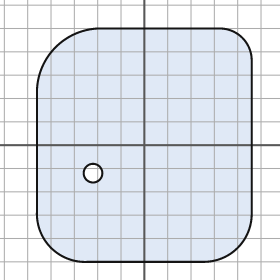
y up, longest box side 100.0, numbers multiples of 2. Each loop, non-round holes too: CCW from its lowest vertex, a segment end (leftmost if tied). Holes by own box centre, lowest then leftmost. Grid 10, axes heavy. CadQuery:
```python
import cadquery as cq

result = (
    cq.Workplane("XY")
    .moveTo(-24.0, -50.0)
    .lineTo(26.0, -50.0)
    .threePointArc((40.0, -44.0), (46.0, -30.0))
    .lineTo(46.0, 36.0)
    .threePointArc((42.0, 46.0), (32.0, 50.0))
    .lineTo(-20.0, 50.0)
    .threePointArc((-38.0, 42.0), (-46.0, 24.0))
    .lineTo(-46.0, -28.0)
    .threePointArc((-40.0, -44.0), (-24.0, -50.0))
    .close()
    .moveTo(-22.0, -12.0)
    .circle(4.0)
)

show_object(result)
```